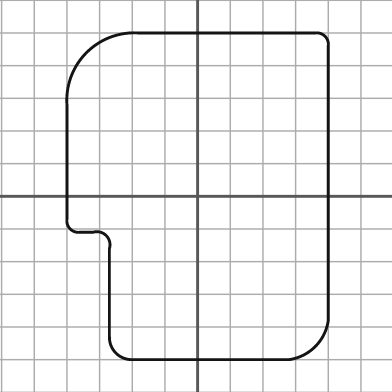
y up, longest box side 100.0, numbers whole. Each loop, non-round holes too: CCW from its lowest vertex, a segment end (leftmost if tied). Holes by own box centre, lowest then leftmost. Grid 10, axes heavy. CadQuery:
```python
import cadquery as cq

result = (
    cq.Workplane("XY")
    .moveTo(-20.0, -50.0)
    .lineTo(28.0, -50.0)
    .threePointArc((36.0, -46.0), (40.0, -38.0))
    .lineTo(40.0, 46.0)
    .threePointArc((39.0, 49.0), (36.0, 50.0))
    .lineTo(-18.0, 50.0)
    .threePointArc((-34.0, 44.0), (-40.0, 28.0))
    .lineTo(-40.0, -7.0)
    .threePointArc((-39.0, -10.0), (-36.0, -11.0))
    .lineTo(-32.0, -11.0)
    .threePointArc((-28.0, -12.0), (-27.0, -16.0))
    .lineTo(-27.0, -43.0)
    .threePointArc((-25.0, -48.0), (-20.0, -50.0))
    .close()
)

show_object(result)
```